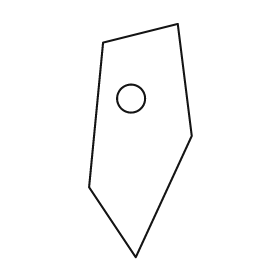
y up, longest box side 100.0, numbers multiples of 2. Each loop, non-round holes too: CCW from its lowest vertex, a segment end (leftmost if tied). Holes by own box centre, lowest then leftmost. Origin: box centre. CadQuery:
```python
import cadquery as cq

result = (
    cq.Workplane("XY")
    .moveTo(-2.0, -50.0)
    .lineTo(22.0, 2.0)
    .lineTo(16.0, 50.0)
    .lineTo(-16.0, 42.0)
    .lineTo(-22.0, -20.0)
    .close()
    .moveTo(-4.0, 18.0)
    .circle(6.0)
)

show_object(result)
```